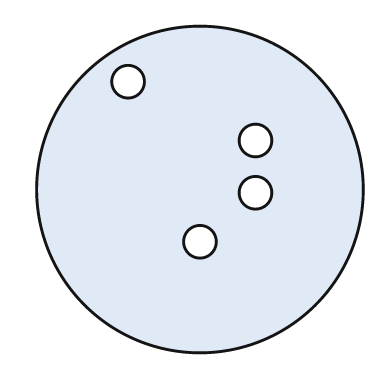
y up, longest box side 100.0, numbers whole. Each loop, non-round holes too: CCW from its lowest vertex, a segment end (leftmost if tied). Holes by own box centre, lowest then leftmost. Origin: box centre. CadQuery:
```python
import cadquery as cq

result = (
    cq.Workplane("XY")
    .moveTo(0.0, 0.0)
    .circle(50.0)
    .moveTo(0.0, -16.0)
    .circle(5.0)
    .moveTo(17.0, -1.0)
    .circle(5.0)
    .moveTo(17.0, 15.0)
    .circle(5.0)
    .moveTo(-22.0, 33.0)
    .circle(5.0)
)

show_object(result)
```